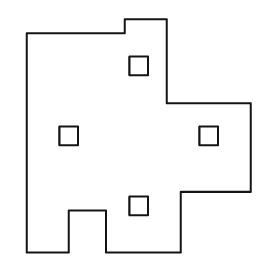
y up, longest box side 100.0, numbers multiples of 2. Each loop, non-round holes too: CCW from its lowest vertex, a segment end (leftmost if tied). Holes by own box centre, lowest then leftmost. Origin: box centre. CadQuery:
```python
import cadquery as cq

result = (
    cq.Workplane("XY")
    .moveTo(-48.0, -50.0)
    .lineTo(-30.0, -50.0)
    .lineTo(-30.0, -32.0)
    .lineTo(-14.0, -32.0)
    .lineTo(-14.0, -50.0)
    .lineTo(18.0, -50.0)
    .lineTo(18.0, -24.0)
    .lineTo(48.0, -24.0)
    .lineTo(48.0, 14.0)
    .lineTo(12.0, 14.0)
    .lineTo(12.0, 50.0)
    .lineTo(-6.0, 50.0)
    .lineTo(-6.0, 44.0)
    .lineTo(-48.0, 44.0)
    .close()
    .moveTo(-4.0, -34.0)
    .lineTo(4.0, -34.0)
    .lineTo(4.0, -26.0)
    .lineTo(-4.0, -26.0)
    .close()
    .moveTo(-34.0, -4.0)
    .lineTo(-26.0, -4.0)
    .lineTo(-26.0, 4.0)
    .lineTo(-34.0, 4.0)
    .close()
    .moveTo(26.0, -4.0)
    .lineTo(34.0, -4.0)
    .lineTo(34.0, 4.0)
    .lineTo(26.0, 4.0)
    .close()
    .moveTo(-4.0, 26.0)
    .lineTo(4.0, 26.0)
    .lineTo(4.0, 34.0)
    .lineTo(-4.0, 34.0)
    .close()
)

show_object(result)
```